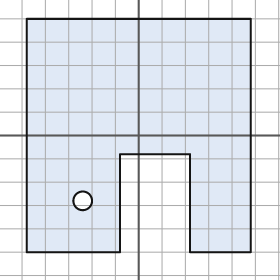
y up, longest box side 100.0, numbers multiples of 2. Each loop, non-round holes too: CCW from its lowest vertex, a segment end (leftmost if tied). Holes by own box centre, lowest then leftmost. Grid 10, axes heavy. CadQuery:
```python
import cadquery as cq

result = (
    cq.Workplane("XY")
    .moveTo(-48.0, -50.0)
    .lineTo(-8.0, -50.0)
    .lineTo(-8.0, -8.0)
    .lineTo(22.0, -8.0)
    .lineTo(22.0, -50.0)
    .lineTo(48.0, -50.0)
    .lineTo(48.0, 50.0)
    .lineTo(-48.0, 50.0)
    .close()
    .moveTo(-24.0, -28.0)
    .circle(4.0)
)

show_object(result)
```